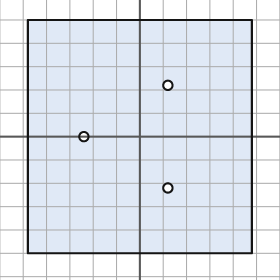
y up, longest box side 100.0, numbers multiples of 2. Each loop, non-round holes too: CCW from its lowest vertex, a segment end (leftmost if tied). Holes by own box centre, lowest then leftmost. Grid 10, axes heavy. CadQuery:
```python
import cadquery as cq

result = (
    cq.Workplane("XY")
    .moveTo(-48.0, -50.0)
    .lineTo(48.0, -50.0)
    .lineTo(48.0, 50.0)
    .lineTo(-48.0, 50.0)
    .close()
    .moveTo(12.0, -22.0)
    .circle(2.0)
    .moveTo(-24.0, 0.0)
    .circle(2.0)
    .moveTo(12.0, 22.0)
    .circle(2.0)
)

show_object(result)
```